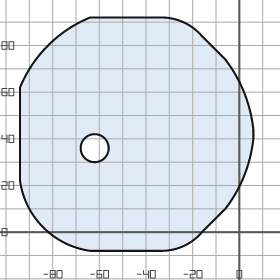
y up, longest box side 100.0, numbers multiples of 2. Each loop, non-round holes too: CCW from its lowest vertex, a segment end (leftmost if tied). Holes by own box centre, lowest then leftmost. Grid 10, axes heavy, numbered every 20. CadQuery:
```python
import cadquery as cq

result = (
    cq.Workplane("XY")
    .moveTo(-64.0, -8.0)
    .lineTo(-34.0, -8.0)
    .threePointArc((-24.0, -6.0), (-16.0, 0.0))
    .lineTo(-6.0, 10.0)
    .threePointArc((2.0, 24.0), (6.0, 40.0))
    .lineTo(6.0, 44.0)
    .threePointArc((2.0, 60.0), (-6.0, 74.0))
    .lineTo(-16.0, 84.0)
    .threePointArc((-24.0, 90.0), (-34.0, 92.0))
    .lineTo(-64.0, 92.0)
    .threePointArc((-82.0, 80.0), (-94.0, 62.0))
    .lineTo(-94.0, 22.0)
    .threePointArc((-84.0, 2.0), (-64.0, -8.0))
    .close()
    .moveTo(-62.0, 36.0)
    .circle(6.0)
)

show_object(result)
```